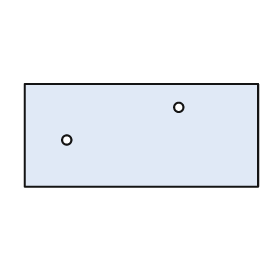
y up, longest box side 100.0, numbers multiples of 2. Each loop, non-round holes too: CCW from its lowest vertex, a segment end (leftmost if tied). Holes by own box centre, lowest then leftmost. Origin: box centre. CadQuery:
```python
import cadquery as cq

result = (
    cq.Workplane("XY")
    .moveTo(-50.0, -22.0)
    .lineTo(50.0, -22.0)
    .lineTo(50.0, 22.0)
    .lineTo(-50.0, 22.0)
    .close()
    .moveTo(-32.0, -2.0)
    .circle(2.0)
    .moveTo(16.0, 12.0)
    .circle(2.0)
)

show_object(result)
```